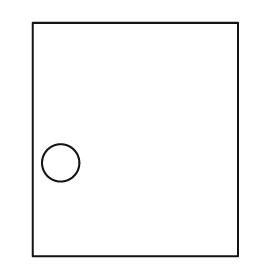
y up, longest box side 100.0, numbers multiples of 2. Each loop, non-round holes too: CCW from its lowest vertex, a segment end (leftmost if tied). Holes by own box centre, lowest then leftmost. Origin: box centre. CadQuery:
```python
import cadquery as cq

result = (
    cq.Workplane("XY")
    .moveTo(-44.0, -50.0)
    .lineTo(44.0, -50.0)
    .lineTo(44.0, 50.0)
    .lineTo(-44.0, 50.0)
    .close()
    .moveTo(-32.0, -10.0)
    .circle(8.0)
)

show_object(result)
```